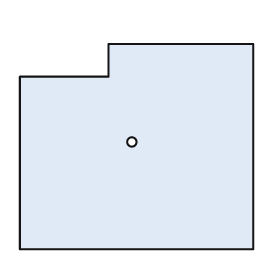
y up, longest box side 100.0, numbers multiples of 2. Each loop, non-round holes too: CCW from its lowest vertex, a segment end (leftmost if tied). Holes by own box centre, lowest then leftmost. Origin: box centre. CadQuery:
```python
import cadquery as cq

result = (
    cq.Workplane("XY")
    .moveTo(-50.0, -44.0)
    .lineTo(50.0, -44.0)
    .lineTo(50.0, 44.0)
    .lineTo(-12.0, 44.0)
    .lineTo(-12.0, 30.0)
    .lineTo(-50.0, 30.0)
    .close()
    .moveTo(-2.0, 2.0)
    .circle(2.0)
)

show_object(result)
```